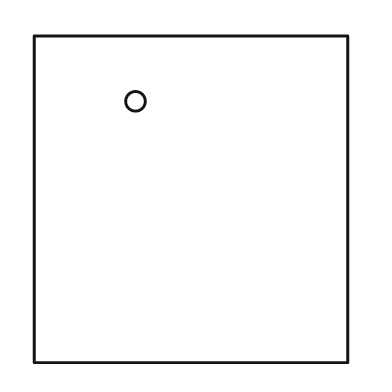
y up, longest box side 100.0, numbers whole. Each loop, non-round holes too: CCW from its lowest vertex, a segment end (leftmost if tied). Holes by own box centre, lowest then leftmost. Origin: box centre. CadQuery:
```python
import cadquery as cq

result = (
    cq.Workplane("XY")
    .moveTo(-48.0, -50.0)
    .lineTo(48.0, -50.0)
    .lineTo(48.0, 50.0)
    .lineTo(-48.0, 50.0)
    .close()
    .moveTo(-17.0, 30.0)
    .circle(3.0)
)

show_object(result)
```